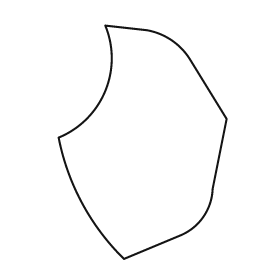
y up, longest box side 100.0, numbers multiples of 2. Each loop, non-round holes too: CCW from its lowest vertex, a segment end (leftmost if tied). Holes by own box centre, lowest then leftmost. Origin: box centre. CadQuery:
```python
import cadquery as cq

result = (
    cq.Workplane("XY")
    .moveTo(-8.0, -50.0)
    .lineTo(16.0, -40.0)
    .threePointArc((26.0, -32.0), (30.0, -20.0))
    .lineTo(36.0, 10.0)
    .lineTo(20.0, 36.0)
    .threePointArc((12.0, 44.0), (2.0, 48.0))
    .lineTo(-16.0, 50.0)
    .threePointArc((-16.0, 22.0), (-36.0, 2.0))
    .threePointArc((-26.0, -26.0), (-8.0, -50.0))
    .close()
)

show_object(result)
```